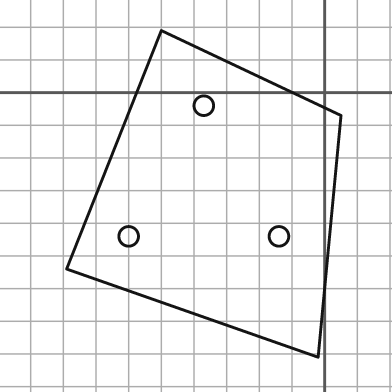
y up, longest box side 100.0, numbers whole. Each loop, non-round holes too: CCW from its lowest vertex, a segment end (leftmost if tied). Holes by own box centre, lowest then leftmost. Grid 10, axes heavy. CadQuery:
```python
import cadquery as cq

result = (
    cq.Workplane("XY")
    .moveTo(-2.0, -81.0)
    .lineTo(5.0, -7.0)
    .lineTo(-50.0, 19.0)
    .lineTo(-79.0, -54.0)
    .close()
    .moveTo(-60.0, -44.0)
    .circle(3.0)
    .moveTo(-14.0, -44.0)
    .circle(3.0)
    .moveTo(-37.0, -4.0)
    .circle(3.0)
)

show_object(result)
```